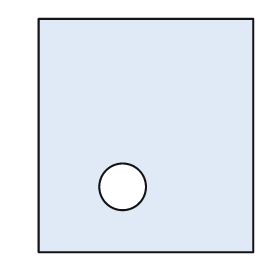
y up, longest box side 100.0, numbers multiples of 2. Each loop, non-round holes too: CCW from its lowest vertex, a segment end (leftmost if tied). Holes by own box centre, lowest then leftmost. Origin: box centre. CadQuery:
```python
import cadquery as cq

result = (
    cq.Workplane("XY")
    .moveTo(-46.0, -50.0)
    .lineTo(46.0, -50.0)
    .lineTo(46.0, 50.0)
    .lineTo(-46.0, 50.0)
    .close()
    .moveTo(-10.0, -22.0)
    .circle(10.0)
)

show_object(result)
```